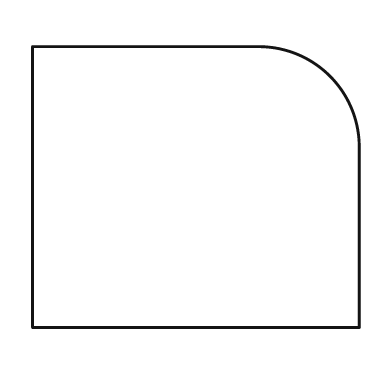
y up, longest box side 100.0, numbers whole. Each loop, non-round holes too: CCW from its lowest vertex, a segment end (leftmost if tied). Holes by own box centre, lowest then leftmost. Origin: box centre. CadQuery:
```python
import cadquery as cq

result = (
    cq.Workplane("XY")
    .moveTo(-50.0, -43.0)
    .lineTo(50.0, -43.0)
    .lineTo(50.0, 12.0)
    .threePointArc((41.0, 34.0), (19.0, 43.0))
    .lineTo(-50.0, 43.0)
    .close()
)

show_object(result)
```